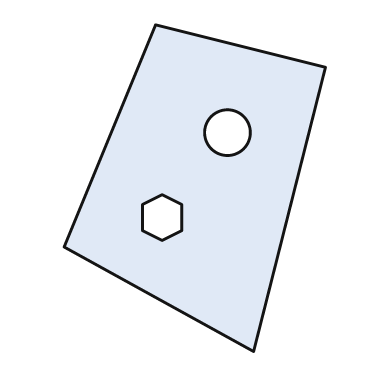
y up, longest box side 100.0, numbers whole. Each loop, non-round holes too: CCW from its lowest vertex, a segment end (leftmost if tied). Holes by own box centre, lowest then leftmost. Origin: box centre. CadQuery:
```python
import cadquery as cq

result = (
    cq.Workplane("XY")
    .moveTo(18.0, -50.0)
    .lineTo(40.0, 37.0)
    .lineTo(-12.0, 50.0)
    .lineTo(-40.0, -18.0)
    .close()
    .moveTo(-10.0, -16.0)
    .lineTo(-4.0, -13.0)
    .lineTo(-4.0, -5.0)
    .lineTo(-10.0, -2.0)
    .lineTo(-16.0, -5.0)
    .lineTo(-16.0, -13.0)
    .close()
    .moveTo(10.0, 17.0)
    .circle(7.0)
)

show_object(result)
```